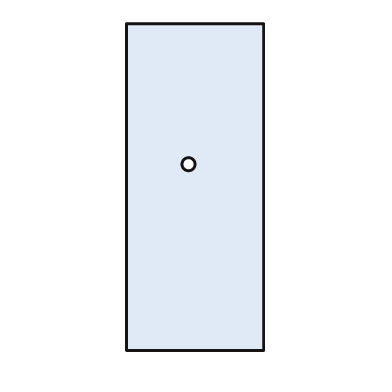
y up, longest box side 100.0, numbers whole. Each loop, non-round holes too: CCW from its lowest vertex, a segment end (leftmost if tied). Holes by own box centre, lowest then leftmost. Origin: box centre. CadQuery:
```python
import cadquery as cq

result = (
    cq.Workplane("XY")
    .moveTo(-21.0, -50.0)
    .lineTo(21.0, -50.0)
    .lineTo(21.0, 50.0)
    .lineTo(-21.0, 50.0)
    .close()
    .moveTo(-2.0, 7.0)
    .circle(2.0)
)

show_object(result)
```